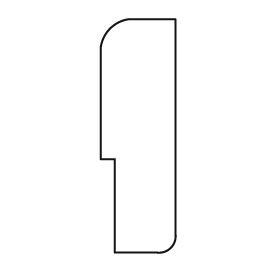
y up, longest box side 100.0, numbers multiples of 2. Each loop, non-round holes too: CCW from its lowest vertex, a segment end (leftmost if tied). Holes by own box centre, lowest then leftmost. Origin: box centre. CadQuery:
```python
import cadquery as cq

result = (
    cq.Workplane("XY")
    .moveTo(-10.0, -50.0)
    .lineTo(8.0, -50.0)
    .threePointArc((14.0, -48.0), (16.0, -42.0))
    .lineTo(16.0, 50.0)
    .lineTo(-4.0, 50.0)
    .threePointArc((-12.0, 46.0), (-16.0, 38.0))
    .lineTo(-16.0, -10.0)
    .lineTo(-10.0, -10.0)
    .close()
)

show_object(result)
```